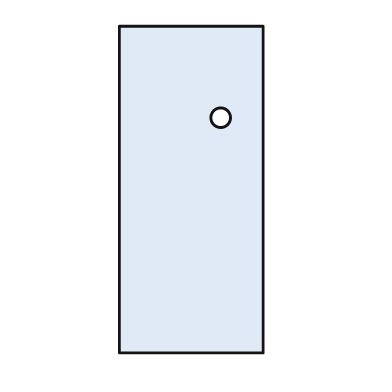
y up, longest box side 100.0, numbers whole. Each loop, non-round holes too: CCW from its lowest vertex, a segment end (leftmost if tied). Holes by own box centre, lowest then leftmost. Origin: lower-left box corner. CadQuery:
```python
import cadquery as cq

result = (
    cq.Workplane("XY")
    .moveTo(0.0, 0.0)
    .lineTo(44.0, 0.0)
    .lineTo(44.0, 100.0)
    .lineTo(0.0, 100.0)
    .close()
    .moveTo(31.0, 72.0)
    .circle(3.0)
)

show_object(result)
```